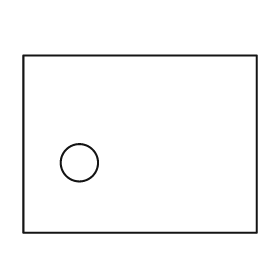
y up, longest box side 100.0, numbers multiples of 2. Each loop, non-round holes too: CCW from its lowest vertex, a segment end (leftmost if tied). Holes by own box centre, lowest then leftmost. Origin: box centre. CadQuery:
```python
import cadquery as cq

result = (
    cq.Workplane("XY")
    .moveTo(-50.0, -38.0)
    .lineTo(50.0, -38.0)
    .lineTo(50.0, 38.0)
    .lineTo(-50.0, 38.0)
    .close()
    .moveTo(-26.0, -8.0)
    .circle(8.0)
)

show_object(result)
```